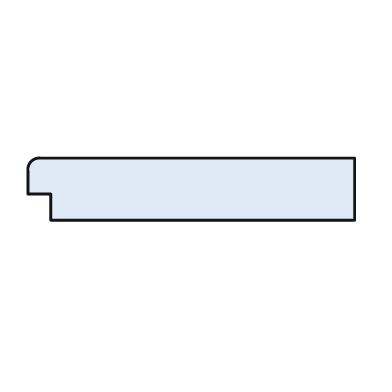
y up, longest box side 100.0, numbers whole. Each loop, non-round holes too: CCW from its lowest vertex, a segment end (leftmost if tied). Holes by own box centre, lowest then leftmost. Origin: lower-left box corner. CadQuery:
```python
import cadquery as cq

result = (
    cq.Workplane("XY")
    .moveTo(7.0, 0.0)
    .lineTo(100.0, 0.0)
    .lineTo(100.0, 19.0)
    .lineTo(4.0, 19.0)
    .threePointArc((1.0, 18.0), (0.0, 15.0))
    .lineTo(0.0, 8.0)
    .lineTo(7.0, 8.0)
    .close()
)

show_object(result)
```